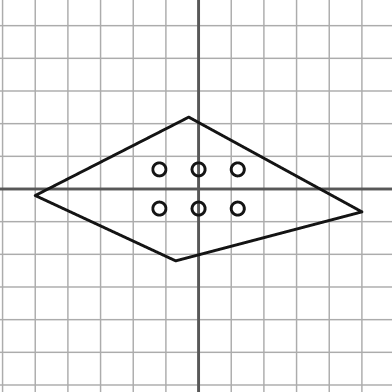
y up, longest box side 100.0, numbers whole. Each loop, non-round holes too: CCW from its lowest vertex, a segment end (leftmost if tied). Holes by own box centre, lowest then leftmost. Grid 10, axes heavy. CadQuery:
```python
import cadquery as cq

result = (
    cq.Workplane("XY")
    .moveTo(-7.0, -22.0)
    .lineTo(50.0, -7.0)
    .lineTo(-3.0, 22.0)
    .lineTo(-50.0, -2.0)
    .close()
    .moveTo(-12.0, -6.0)
    .circle(2.0)
    .moveTo(0.0, -6.0)
    .circle(2.0)
    .moveTo(12.0, -6.0)
    .circle(2.0)
    .moveTo(-12.0, 6.0)
    .circle(2.0)
    .moveTo(0.0, 6.0)
    .circle(2.0)
    .moveTo(12.0, 6.0)
    .circle(2.0)
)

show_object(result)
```